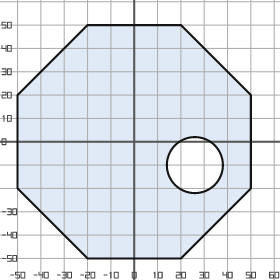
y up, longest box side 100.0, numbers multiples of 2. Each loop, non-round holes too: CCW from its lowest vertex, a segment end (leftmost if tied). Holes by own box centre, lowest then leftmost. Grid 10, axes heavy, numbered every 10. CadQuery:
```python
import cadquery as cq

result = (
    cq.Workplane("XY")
    .moveTo(-20.0, -50.0)
    .lineTo(20.0, -50.0)
    .lineTo(50.0, -20.0)
    .lineTo(50.0, 20.0)
    .lineTo(20.0, 50.0)
    .lineTo(-20.0, 50.0)
    .lineTo(-50.0, 20.0)
    .lineTo(-50.0, -20.0)
    .close()
    .moveTo(26.0, -10.0)
    .circle(12.0)
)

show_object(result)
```